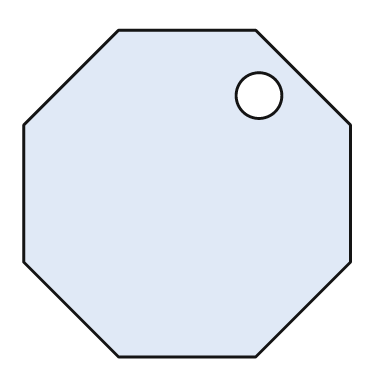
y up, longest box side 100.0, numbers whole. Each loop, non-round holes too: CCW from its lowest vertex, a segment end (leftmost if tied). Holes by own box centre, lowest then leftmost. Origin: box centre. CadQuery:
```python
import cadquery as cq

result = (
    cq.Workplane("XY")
    .moveTo(-21.0, -50.0)
    .lineTo(21.0, -50.0)
    .lineTo(50.0, -21.0)
    .lineTo(50.0, 21.0)
    .lineTo(21.0, 50.0)
    .lineTo(-21.0, 50.0)
    .lineTo(-50.0, 21.0)
    .lineTo(-50.0, -21.0)
    .close()
    .moveTo(22.0, 30.0)
    .circle(7.0)
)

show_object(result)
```